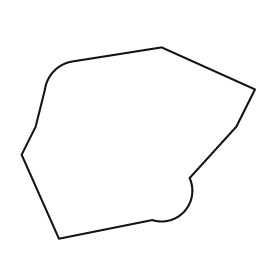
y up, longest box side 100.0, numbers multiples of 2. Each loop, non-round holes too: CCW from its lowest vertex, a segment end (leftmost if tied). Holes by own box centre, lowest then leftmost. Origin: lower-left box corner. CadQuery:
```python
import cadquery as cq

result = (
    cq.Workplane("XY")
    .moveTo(16.0, 0.0)
    .lineTo(56.0, 8.0)
    .threePointArc((70.0, 12.0), (72.0, 26.0))
    .lineTo(92.0, 48.0)
    .lineTo(100.0, 64.0)
    .lineTo(60.0, 82.0)
    .lineTo(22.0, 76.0)
    .threePointArc((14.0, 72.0), (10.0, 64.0))
    .lineTo(6.0, 48.0)
    .lineTo(0.0, 36.0)
    .close()
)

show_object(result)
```